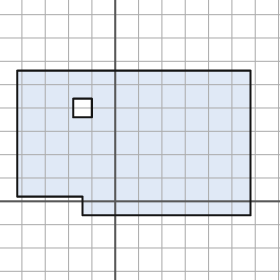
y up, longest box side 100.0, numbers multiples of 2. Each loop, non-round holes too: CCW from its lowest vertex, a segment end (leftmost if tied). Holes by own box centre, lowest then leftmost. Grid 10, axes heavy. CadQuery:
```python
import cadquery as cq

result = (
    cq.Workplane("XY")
    .moveTo(-14.0, -6.0)
    .lineTo(58.0, -6.0)
    .lineTo(58.0, 56.0)
    .lineTo(-42.0, 56.0)
    .lineTo(-42.0, 2.0)
    .lineTo(-14.0, 2.0)
    .close()
    .moveTo(-18.0, 36.0)
    .lineTo(-10.0, 36.0)
    .lineTo(-10.0, 44.0)
    .lineTo(-18.0, 44.0)
    .close()
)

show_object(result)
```